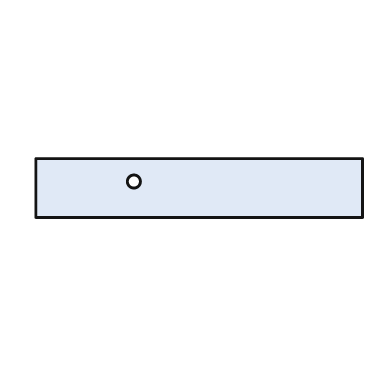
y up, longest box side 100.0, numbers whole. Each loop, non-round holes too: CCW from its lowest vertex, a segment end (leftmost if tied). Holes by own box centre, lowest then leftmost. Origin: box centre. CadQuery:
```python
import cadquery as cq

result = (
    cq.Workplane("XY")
    .moveTo(-50.0, -9.0)
    .lineTo(50.0, -9.0)
    .lineTo(50.0, 9.0)
    .lineTo(-50.0, 9.0)
    .close()
    .moveTo(-20.0, 2.0)
    .circle(2.0)
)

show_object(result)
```